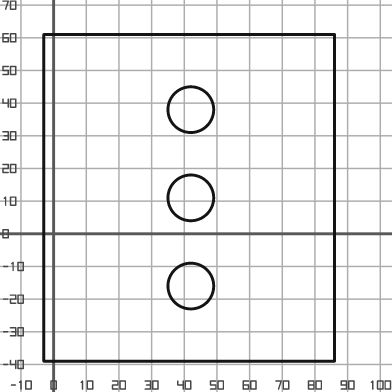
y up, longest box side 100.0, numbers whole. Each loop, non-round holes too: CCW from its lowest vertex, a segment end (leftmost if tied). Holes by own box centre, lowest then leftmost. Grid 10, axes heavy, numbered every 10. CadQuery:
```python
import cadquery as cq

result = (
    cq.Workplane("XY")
    .moveTo(-3.0, -39.0)
    .lineTo(86.0, -39.0)
    .lineTo(86.0, 61.0)
    .lineTo(-3.0, 61.0)
    .close()
    .moveTo(42.0, -16.0)
    .circle(7.0)
    .moveTo(42.0, 11.0)
    .circle(7.0)
    .moveTo(42.0, 38.0)
    .circle(7.0)
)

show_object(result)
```